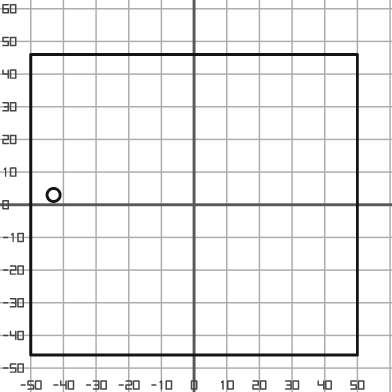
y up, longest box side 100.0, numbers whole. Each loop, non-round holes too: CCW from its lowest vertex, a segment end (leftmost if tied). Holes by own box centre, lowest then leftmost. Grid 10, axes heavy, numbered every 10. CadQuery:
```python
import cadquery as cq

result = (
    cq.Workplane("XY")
    .moveTo(-50.0, -46.0)
    .lineTo(50.0, -46.0)
    .lineTo(50.0, 46.0)
    .lineTo(-50.0, 46.0)
    .close()
    .moveTo(-43.0, 3.0)
    .circle(2.0)
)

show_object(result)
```